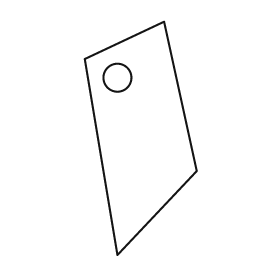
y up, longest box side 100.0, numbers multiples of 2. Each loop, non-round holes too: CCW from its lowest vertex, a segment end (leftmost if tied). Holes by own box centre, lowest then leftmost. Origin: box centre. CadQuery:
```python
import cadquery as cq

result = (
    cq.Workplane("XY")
    .moveTo(-10.0, -50.0)
    .lineTo(24.0, -14.0)
    .lineTo(10.0, 50.0)
    .lineTo(-24.0, 34.0)
    .close()
    .moveTo(-10.0, 26.0)
    .circle(6.0)
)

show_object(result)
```